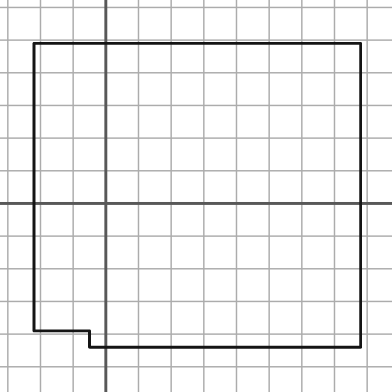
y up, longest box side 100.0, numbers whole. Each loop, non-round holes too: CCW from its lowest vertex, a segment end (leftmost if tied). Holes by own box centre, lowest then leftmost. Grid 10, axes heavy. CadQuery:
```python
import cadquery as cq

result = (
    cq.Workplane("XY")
    .moveTo(-5.0, -44.0)
    .lineTo(78.0, -44.0)
    .lineTo(78.0, 49.0)
    .lineTo(-22.0, 49.0)
    .lineTo(-22.0, -39.0)
    .lineTo(-5.0, -39.0)
    .close()
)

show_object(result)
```